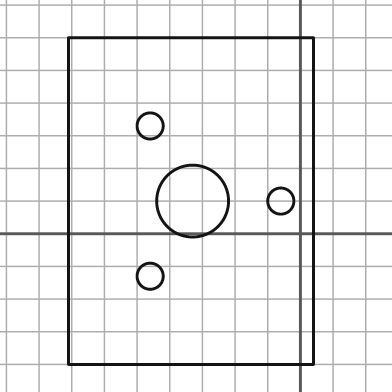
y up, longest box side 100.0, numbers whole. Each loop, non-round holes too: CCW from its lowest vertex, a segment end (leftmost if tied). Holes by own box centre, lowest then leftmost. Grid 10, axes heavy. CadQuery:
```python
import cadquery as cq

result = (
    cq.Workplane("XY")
    .moveTo(-71.0, -40.0)
    .lineTo(4.0, -40.0)
    .lineTo(4.0, 60.0)
    .lineTo(-71.0, 60.0)
    .close()
    .moveTo(-46.0, -13.0)
    .circle(4.0)
    .moveTo(-33.0, 10.0)
    .circle(11.0)
    .moveTo(-6.0, 10.0)
    .circle(4.0)
    .moveTo(-46.0, 33.0)
    .circle(4.0)
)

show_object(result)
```